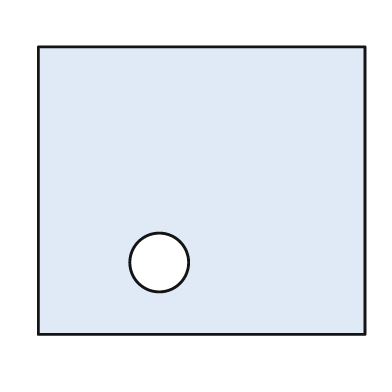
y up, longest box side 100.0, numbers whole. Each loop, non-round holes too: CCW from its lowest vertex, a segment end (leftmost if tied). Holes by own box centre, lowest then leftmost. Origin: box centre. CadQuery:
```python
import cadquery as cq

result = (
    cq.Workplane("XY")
    .moveTo(-50.0, -44.0)
    .lineTo(50.0, -44.0)
    .lineTo(50.0, 44.0)
    .lineTo(-50.0, 44.0)
    .close()
    .moveTo(-13.0, -22.0)
    .circle(9.0)
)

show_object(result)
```